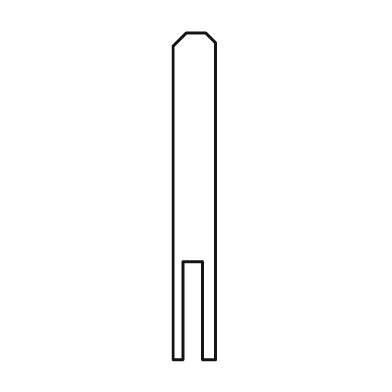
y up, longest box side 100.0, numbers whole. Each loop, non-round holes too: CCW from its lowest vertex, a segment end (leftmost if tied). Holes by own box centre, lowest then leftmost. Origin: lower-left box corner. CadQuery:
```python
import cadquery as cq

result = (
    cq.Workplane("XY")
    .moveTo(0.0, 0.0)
    .lineTo(3.0, 0.0)
    .lineTo(3.0, 30.0)
    .lineTo(9.0, 30.0)
    .lineTo(9.0, 0.0)
    .lineTo(13.0, 0.0)
    .lineTo(13.0, 97.0)
    .lineTo(10.0, 100.0)
    .lineTo(4.0, 100.0)
    .lineTo(0.0, 96.0)
    .close()
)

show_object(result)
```